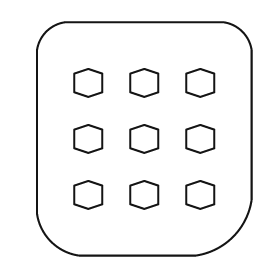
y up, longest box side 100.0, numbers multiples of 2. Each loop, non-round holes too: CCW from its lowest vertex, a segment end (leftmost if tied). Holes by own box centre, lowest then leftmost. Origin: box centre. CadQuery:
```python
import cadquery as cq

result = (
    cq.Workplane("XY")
    .moveTo(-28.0, -50.0)
    .lineTo(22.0, -50.0)
    .threePointArc((38.0, -42.0), (46.0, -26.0))
    .lineTo(46.0, 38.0)
    .threePointArc((42.0, 46.0), (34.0, 50.0))
    .lineTo(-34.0, 50.0)
    .threePointArc((-42.0, 46.0), (-46.0, 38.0))
    .lineTo(-46.0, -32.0)
    .threePointArc((-40.0, -44.0), (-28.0, -50.0))
    .close()
    .moveTo(-24.0, -30.0)
    .lineTo(-18.0, -28.0)
    .lineTo(-18.0, -20.0)
    .lineTo(-24.0, -18.0)
    .lineTo(-30.0, -20.0)
    .lineTo(-30.0, -28.0)
    .close()
    .moveTo(0.0, -30.0)
    .lineTo(6.0, -28.0)
    .lineTo(6.0, -20.0)
    .lineTo(0.0, -18.0)
    .lineTo(-6.0, -20.0)
    .lineTo(-6.0, -28.0)
    .close()
    .moveTo(24.0, -30.0)
    .lineTo(30.0, -28.0)
    .lineTo(30.0, -20.0)
    .lineTo(24.0, -18.0)
    .lineTo(18.0, -20.0)
    .lineTo(18.0, -28.0)
    .close()
    .moveTo(-24.0, -6.0)
    .lineTo(-18.0, -4.0)
    .lineTo(-18.0, 4.0)
    .lineTo(-24.0, 6.0)
    .lineTo(-30.0, 4.0)
    .lineTo(-30.0, -4.0)
    .close()
    .moveTo(0.0, -6.0)
    .lineTo(6.0, -4.0)
    .lineTo(6.0, 4.0)
    .lineTo(0.0, 6.0)
    .lineTo(-6.0, 4.0)
    .lineTo(-6.0, -4.0)
    .close()
    .moveTo(24.0, -6.0)
    .lineTo(30.0, -4.0)
    .lineTo(30.0, 4.0)
    .lineTo(24.0, 6.0)
    .lineTo(18.0, 4.0)
    .lineTo(18.0, -4.0)
    .close()
    .moveTo(-24.0, 18.0)
    .lineTo(-18.0, 20.0)
    .lineTo(-18.0, 28.0)
    .lineTo(-24.0, 30.0)
    .lineTo(-30.0, 28.0)
    .lineTo(-30.0, 20.0)
    .close()
    .moveTo(0.0, 18.0)
    .lineTo(6.0, 20.0)
    .lineTo(6.0, 28.0)
    .lineTo(0.0, 30.0)
    .lineTo(-6.0, 28.0)
    .lineTo(-6.0, 20.0)
    .close()
    .moveTo(24.0, 18.0)
    .lineTo(30.0, 20.0)
    .lineTo(30.0, 28.0)
    .lineTo(24.0, 30.0)
    .lineTo(18.0, 28.0)
    .lineTo(18.0, 20.0)
    .close()
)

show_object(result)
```